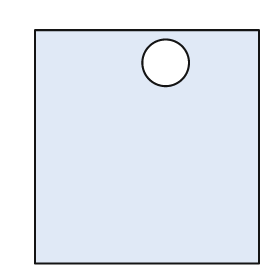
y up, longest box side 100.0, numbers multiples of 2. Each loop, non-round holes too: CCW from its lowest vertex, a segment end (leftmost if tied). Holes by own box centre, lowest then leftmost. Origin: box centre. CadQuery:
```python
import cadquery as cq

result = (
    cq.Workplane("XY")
    .moveTo(-48.0, -50.0)
    .lineTo(48.0, -50.0)
    .lineTo(48.0, 50.0)
    .lineTo(-48.0, 50.0)
    .close()
    .moveTo(8.0, 36.0)
    .circle(10.0)
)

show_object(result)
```